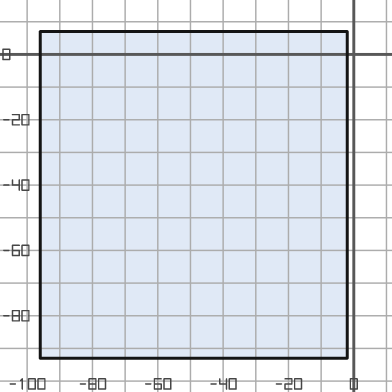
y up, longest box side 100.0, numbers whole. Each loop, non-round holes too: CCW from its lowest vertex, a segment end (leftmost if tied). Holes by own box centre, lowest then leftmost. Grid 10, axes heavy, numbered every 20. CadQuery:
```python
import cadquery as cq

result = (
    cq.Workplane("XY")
    .moveTo(-96.0, -93.0)
    .lineTo(-2.0, -93.0)
    .lineTo(-2.0, 7.0)
    .lineTo(-96.0, 7.0)
    .close()
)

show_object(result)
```